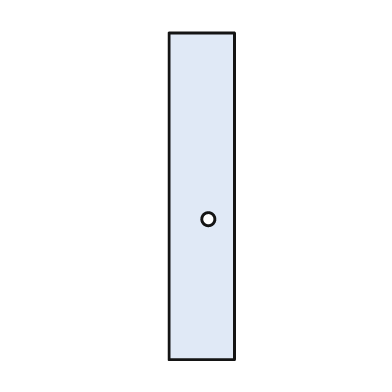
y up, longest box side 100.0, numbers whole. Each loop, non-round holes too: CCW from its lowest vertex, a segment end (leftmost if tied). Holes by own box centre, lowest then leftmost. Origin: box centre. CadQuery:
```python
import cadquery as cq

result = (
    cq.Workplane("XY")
    .moveTo(-10.0, -50.0)
    .lineTo(10.0, -50.0)
    .lineTo(10.0, 50.0)
    .lineTo(-10.0, 50.0)
    .close()
    .moveTo(2.0, -7.0)
    .circle(2.0)
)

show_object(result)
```